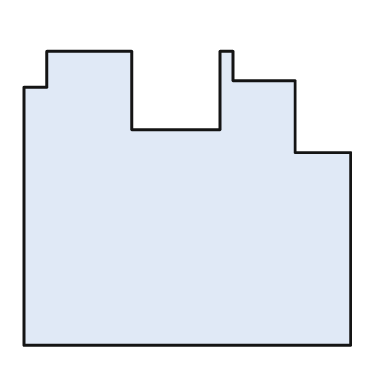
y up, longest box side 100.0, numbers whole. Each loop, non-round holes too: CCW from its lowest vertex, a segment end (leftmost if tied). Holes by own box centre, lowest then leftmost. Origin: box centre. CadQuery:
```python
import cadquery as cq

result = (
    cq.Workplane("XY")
    .moveTo(-50.0, -45.0)
    .lineTo(50.0, -45.0)
    .lineTo(50.0, 14.0)
    .lineTo(33.0, 14.0)
    .lineTo(33.0, 36.0)
    .lineTo(14.0, 36.0)
    .lineTo(14.0, 45.0)
    .lineTo(10.0, 45.0)
    .lineTo(10.0, 21.0)
    .lineTo(-17.0, 21.0)
    .lineTo(-17.0, 45.0)
    .lineTo(-43.0, 45.0)
    .lineTo(-43.0, 34.0)
    .lineTo(-50.0, 34.0)
    .close()
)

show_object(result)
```